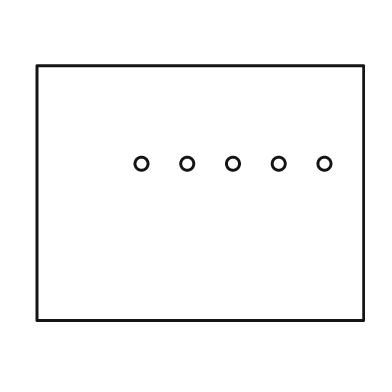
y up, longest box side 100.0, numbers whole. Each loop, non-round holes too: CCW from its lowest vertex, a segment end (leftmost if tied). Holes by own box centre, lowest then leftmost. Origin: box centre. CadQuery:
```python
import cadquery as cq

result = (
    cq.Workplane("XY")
    .moveTo(-50.0, -39.0)
    .lineTo(50.0, -39.0)
    .lineTo(50.0, 39.0)
    .lineTo(-50.0, 39.0)
    .close()
    .moveTo(-18.0, 9.0)
    .circle(2.0)
    .moveTo(-4.0, 9.0)
    .circle(2.0)
    .moveTo(10.0, 9.0)
    .circle(2.0)
    .moveTo(24.0, 9.0)
    .circle(2.0)
    .moveTo(38.0, 9.0)
    .circle(2.0)
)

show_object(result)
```